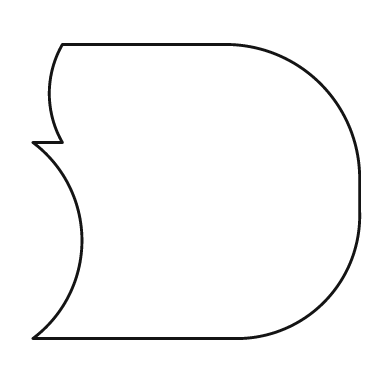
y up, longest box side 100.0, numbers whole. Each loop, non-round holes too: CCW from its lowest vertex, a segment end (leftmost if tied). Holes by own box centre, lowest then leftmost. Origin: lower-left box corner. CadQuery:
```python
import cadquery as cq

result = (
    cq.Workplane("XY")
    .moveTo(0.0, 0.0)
    .lineTo(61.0, 0.0)
    .threePointArc((89.0, 11.0), (100.0, 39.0))
    .lineTo(100.0, 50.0)
    .threePointArc((88.0, 78.0), (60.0, 90.0))
    .lineTo(9.0, 90.0)
    .threePointArc((5.0, 75.0), (9.0, 60.0))
    .lineTo(0.0, 60.0)
    .threePointArc((15.0, 30.0), (0.0, 0.0))
    .close()
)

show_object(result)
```